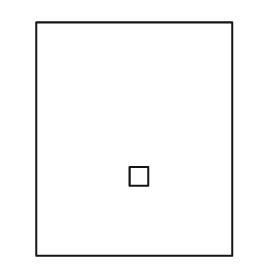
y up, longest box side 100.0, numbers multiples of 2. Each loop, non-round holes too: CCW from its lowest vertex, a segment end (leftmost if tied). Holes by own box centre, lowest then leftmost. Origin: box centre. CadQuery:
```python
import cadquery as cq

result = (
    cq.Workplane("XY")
    .moveTo(-42.0, -50.0)
    .lineTo(42.0, -50.0)
    .lineTo(42.0, 50.0)
    .lineTo(-42.0, 50.0)
    .close()
    .moveTo(-2.0, -20.0)
    .lineTo(6.0, -20.0)
    .lineTo(6.0, -12.0)
    .lineTo(-2.0, -12.0)
    .close()
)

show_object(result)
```